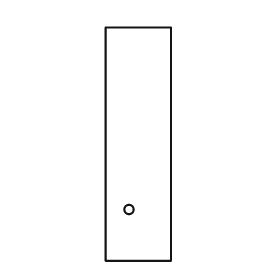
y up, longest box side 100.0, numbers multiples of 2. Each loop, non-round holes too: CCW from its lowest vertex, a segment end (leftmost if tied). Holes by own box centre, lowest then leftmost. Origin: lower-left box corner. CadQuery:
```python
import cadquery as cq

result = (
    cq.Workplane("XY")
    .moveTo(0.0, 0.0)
    .lineTo(28.0, 0.0)
    .lineTo(28.0, 100.0)
    .lineTo(0.0, 100.0)
    .close()
    .moveTo(10.0, 22.0)
    .circle(2.0)
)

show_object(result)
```